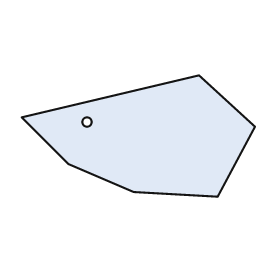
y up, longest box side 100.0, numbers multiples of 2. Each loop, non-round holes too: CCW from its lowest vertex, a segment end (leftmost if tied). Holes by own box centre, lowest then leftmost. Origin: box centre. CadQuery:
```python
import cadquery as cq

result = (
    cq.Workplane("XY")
    .moveTo(34.0, -26.0)
    .lineTo(50.0, 4.0)
    .lineTo(26.0, 26.0)
    .lineTo(-50.0, 8.0)
    .lineTo(-30.0, -12.0)
    .lineTo(-2.0, -24.0)
    .close()
    .moveTo(-22.0, 6.0)
    .circle(2.0)
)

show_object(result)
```